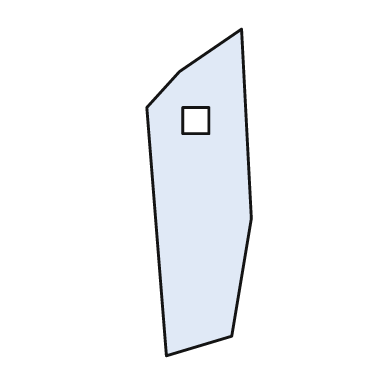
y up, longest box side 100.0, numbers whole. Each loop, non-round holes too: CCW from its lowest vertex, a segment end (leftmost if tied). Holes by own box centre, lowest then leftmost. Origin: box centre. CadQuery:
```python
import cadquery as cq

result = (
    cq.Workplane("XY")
    .moveTo(-10.0, -50.0)
    .lineTo(10.0, -44.0)
    .lineTo(16.0, -8.0)
    .lineTo(13.0, 50.0)
    .lineTo(-6.0, 37.0)
    .lineTo(-16.0, 26.0)
    .close()
    .moveTo(-5.0, 18.0)
    .lineTo(3.0, 18.0)
    .lineTo(3.0, 26.0)
    .lineTo(-5.0, 26.0)
    .close()
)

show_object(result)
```